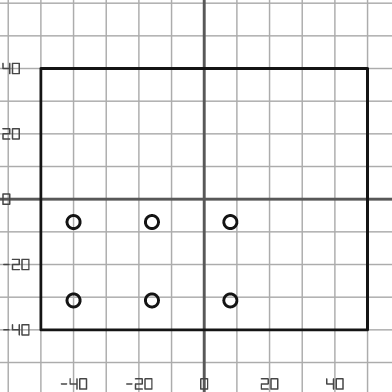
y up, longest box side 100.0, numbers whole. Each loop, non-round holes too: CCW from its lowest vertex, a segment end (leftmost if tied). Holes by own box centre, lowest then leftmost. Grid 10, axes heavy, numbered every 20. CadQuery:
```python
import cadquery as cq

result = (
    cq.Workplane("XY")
    .moveTo(-50.0, -40.0)
    .lineTo(50.0, -40.0)
    .lineTo(50.0, 40.0)
    .lineTo(-50.0, 40.0)
    .close()
    .moveTo(-40.0, -31.0)
    .circle(2.0)
    .moveTo(-16.0, -31.0)
    .circle(2.0)
    .moveTo(8.0, -31.0)
    .circle(2.0)
    .moveTo(-40.0, -7.0)
    .circle(2.0)
    .moveTo(-16.0, -7.0)
    .circle(2.0)
    .moveTo(8.0, -7.0)
    .circle(2.0)
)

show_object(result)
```